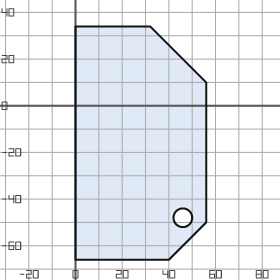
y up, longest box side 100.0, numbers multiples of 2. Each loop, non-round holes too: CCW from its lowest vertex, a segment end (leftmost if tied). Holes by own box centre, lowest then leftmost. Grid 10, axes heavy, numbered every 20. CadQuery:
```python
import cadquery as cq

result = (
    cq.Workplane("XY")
    .moveTo(0.0, -66.0)
    .lineTo(40.0, -66.0)
    .lineTo(56.0, -50.0)
    .lineTo(56.0, 10.0)
    .lineTo(32.0, 34.0)
    .lineTo(0.0, 34.0)
    .close()
    .moveTo(46.0, -48.0)
    .circle(4.0)
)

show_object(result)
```